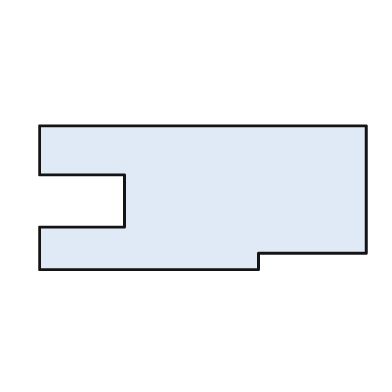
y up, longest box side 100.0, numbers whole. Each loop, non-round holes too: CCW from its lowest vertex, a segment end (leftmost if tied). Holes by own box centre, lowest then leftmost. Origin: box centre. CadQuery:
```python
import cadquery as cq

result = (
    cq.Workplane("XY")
    .moveTo(-50.0, -22.0)
    .lineTo(17.0, -22.0)
    .lineTo(17.0, -17.0)
    .lineTo(50.0, -17.0)
    .lineTo(50.0, 22.0)
    .lineTo(-50.0, 22.0)
    .lineTo(-50.0, 7.0)
    .lineTo(-24.0, 7.0)
    .lineTo(-24.0, -9.0)
    .lineTo(-50.0, -9.0)
    .close()
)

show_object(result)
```